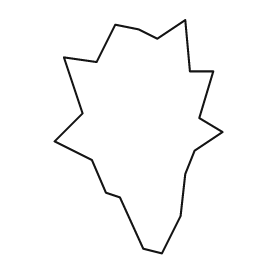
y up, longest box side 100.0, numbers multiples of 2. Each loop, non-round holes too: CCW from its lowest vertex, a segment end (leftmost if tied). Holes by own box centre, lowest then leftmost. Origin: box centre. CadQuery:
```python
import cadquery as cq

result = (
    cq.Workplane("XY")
    .moveTo(10.0, -50.0)
    .lineTo(18.0, -34.0)
    .lineTo(20.0, -16.0)
    .lineTo(24.0, -6.0)
    .lineTo(36.0, 2.0)
    .lineTo(26.0, 8.0)
    .lineTo(32.0, 28.0)
    .lineTo(22.0, 28.0)
    .lineTo(20.0, 50.0)
    .lineTo(8.0, 42.0)
    .lineTo(0.0, 46.0)
    .lineTo(-10.0, 48.0)
    .lineTo(-18.0, 32.0)
    .lineTo(-32.0, 34.0)
    .lineTo(-24.0, 10.0)
    .lineTo(-36.0, -2.0)
    .lineTo(-20.0, -10.0)
    .lineTo(-14.0, -24.0)
    .lineTo(-8.0, -26.0)
    .lineTo(2.0, -48.0)
    .close()
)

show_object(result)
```